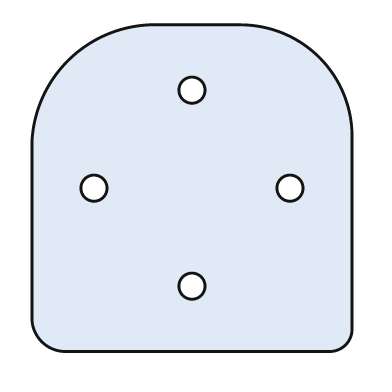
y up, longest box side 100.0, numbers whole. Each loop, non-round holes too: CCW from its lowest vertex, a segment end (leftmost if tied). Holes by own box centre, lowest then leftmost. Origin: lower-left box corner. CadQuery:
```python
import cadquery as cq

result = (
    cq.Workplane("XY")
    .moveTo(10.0, 0.0)
    .lineTo(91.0, 0.0)
    .threePointArc((96.0, 2.0), (98.0, 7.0))
    .lineTo(98.0, 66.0)
    .threePointArc((88.0, 90.0), (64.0, 100.0))
    .lineTo(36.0, 100.0)
    .threePointArc((11.0, 89.0), (0.0, 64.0))
    .lineTo(0.0, 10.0)
    .threePointArc((3.0, 3.0), (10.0, 0.0))
    .close()
    .moveTo(49.0, 20.0)
    .circle(4.0)
    .moveTo(19.0, 50.0)
    .circle(4.0)
    .moveTo(79.0, 50.0)
    .circle(4.0)
    .moveTo(49.0, 80.0)
    .circle(4.0)
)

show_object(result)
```